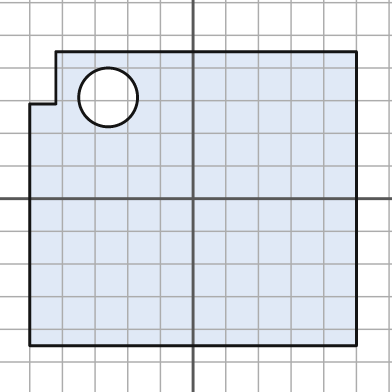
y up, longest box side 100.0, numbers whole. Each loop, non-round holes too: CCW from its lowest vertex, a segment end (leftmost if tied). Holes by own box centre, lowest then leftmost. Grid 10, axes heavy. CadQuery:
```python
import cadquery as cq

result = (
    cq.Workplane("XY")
    .moveTo(-50.0, -45.0)
    .lineTo(50.0, -45.0)
    .lineTo(50.0, 45.0)
    .lineTo(-42.0, 45.0)
    .lineTo(-42.0, 29.0)
    .lineTo(-50.0, 29.0)
    .close()
    .moveTo(-26.0, 31.0)
    .circle(9.0)
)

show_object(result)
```